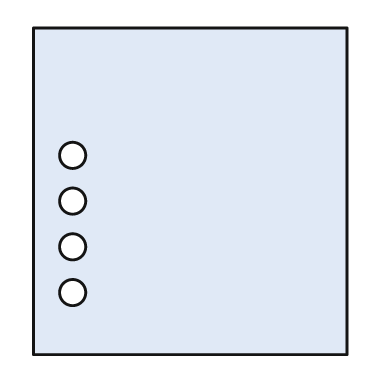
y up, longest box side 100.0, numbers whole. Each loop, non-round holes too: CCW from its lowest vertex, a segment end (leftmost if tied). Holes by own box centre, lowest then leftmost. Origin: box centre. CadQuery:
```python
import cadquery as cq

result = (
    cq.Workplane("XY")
    .moveTo(-48.0, -50.0)
    .lineTo(48.0, -50.0)
    .lineTo(48.0, 50.0)
    .lineTo(-48.0, 50.0)
    .close()
    .moveTo(-36.0, -31.0)
    .circle(4.0)
    .moveTo(-36.0, -17.0)
    .circle(4.0)
    .moveTo(-36.0, -3.0)
    .circle(4.0)
    .moveTo(-36.0, 11.0)
    .circle(4.0)
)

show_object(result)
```